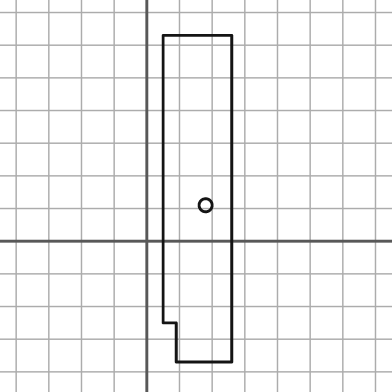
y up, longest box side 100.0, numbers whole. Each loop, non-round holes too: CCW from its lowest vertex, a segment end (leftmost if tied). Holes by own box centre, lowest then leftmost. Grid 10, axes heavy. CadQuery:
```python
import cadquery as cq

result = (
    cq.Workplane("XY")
    .moveTo(9.0, -37.0)
    .lineTo(26.0, -37.0)
    .lineTo(26.0, 63.0)
    .lineTo(5.0, 63.0)
    .lineTo(5.0, -25.0)
    .lineTo(9.0, -25.0)
    .close()
    .moveTo(18.0, 11.0)
    .circle(2.0)
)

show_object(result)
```